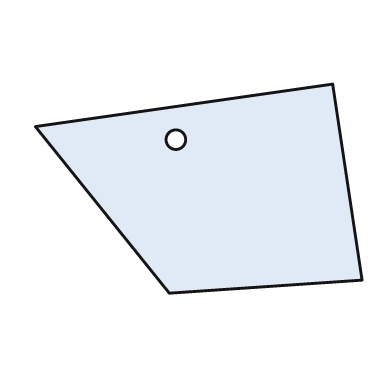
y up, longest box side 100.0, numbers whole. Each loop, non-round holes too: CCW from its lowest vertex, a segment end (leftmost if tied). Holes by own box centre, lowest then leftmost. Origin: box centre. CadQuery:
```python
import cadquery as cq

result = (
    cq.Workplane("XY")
    .moveTo(-9.0, -32.0)
    .lineTo(50.0, -28.0)
    .lineTo(41.0, 32.0)
    .lineTo(-50.0, 19.0)
    .close()
    .moveTo(-7.0, 15.0)
    .circle(3.0)
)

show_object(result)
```